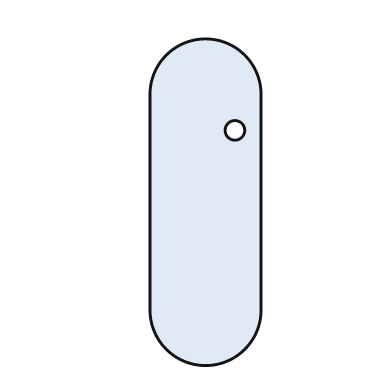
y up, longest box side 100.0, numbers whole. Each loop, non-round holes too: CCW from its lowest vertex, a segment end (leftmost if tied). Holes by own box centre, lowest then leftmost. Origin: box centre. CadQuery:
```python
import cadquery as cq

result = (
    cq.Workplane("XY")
    .moveTo(-17.0, -33.0)
    .threePointArc((0.0, -50.0), (17.0, -33.0))
    .lineTo(17.0, 33.0)
    .threePointArc((0.0, 50.0), (-17.0, 33.0))
    .close()
    .moveTo(9.0, 22.0)
    .circle(3.0)
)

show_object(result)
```